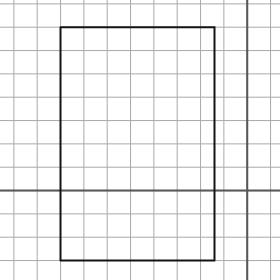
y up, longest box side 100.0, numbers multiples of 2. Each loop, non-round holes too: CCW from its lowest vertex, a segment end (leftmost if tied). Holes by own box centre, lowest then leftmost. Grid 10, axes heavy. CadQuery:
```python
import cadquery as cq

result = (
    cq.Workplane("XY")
    .moveTo(-80.0, -30.0)
    .lineTo(-14.0, -30.0)
    .lineTo(-14.0, 70.0)
    .lineTo(-80.0, 70.0)
    .close()
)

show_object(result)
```